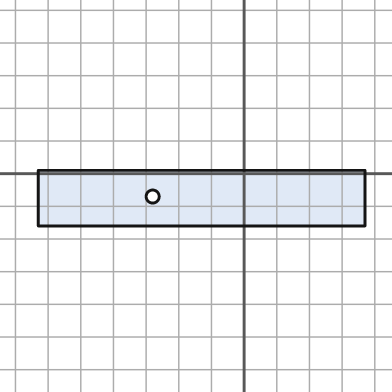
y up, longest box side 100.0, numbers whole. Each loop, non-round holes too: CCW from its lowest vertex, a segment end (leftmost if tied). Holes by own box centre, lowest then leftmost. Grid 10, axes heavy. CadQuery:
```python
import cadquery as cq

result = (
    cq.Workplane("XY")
    .moveTo(-63.0, -16.0)
    .lineTo(37.0, -16.0)
    .lineTo(37.0, 1.0)
    .lineTo(-63.0, 1.0)
    .close()
    .moveTo(-28.0, -7.0)
    .circle(2.0)
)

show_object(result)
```